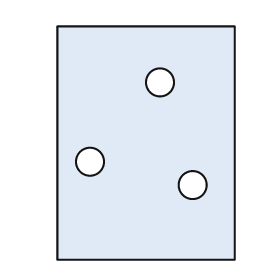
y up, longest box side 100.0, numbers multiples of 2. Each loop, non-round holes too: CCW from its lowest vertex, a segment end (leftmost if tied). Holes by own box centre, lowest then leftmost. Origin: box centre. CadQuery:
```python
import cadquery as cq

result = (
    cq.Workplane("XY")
    .moveTo(-38.0, -50.0)
    .lineTo(38.0, -50.0)
    .lineTo(38.0, 50.0)
    .lineTo(-38.0, 50.0)
    .close()
    .moveTo(20.0, -18.0)
    .circle(6.0)
    .moveTo(-24.0, -8.0)
    .circle(6.0)
    .moveTo(6.0, 26.0)
    .circle(6.0)
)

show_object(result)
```